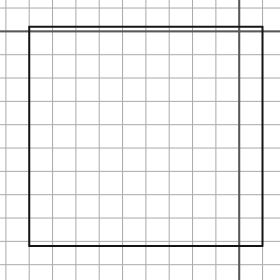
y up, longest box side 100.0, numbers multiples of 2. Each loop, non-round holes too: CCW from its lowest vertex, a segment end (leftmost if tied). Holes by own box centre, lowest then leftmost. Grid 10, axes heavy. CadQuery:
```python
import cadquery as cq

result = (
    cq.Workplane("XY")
    .moveTo(-90.0, -92.0)
    .lineTo(10.0, -92.0)
    .lineTo(10.0, 2.0)
    .lineTo(-90.0, 2.0)
    .close()
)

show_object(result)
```